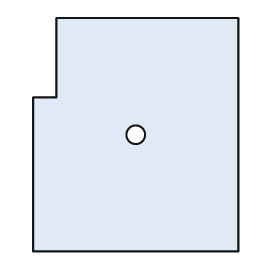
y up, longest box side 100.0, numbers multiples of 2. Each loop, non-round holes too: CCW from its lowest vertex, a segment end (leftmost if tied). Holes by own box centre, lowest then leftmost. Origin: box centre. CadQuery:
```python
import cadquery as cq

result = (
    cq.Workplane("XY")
    .moveTo(-44.0, -50.0)
    .lineTo(44.0, -50.0)
    .lineTo(44.0, 50.0)
    .lineTo(-34.0, 50.0)
    .lineTo(-34.0, 16.0)
    .lineTo(-44.0, 16.0)
    .close()
    .moveTo(0.0, 0.0)
    .circle(4.0)
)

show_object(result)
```